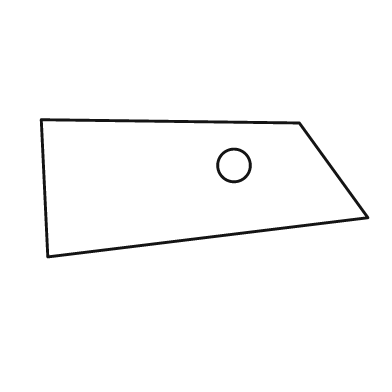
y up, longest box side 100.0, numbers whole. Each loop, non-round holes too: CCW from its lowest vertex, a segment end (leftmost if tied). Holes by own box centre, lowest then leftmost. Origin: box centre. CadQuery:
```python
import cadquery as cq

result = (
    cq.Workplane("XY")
    .moveTo(-48.0, -21.0)
    .lineTo(50.0, -9.0)
    .lineTo(29.0, 20.0)
    .lineTo(-50.0, 21.0)
    .close()
    .moveTo(9.0, 7.0)
    .circle(5.0)
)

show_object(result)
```